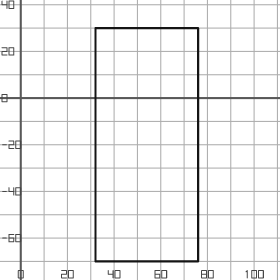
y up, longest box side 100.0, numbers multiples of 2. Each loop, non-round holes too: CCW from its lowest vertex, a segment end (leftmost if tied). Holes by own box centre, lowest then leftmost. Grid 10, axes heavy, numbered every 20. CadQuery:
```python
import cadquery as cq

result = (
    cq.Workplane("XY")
    .moveTo(32.0, -70.0)
    .lineTo(76.0, -70.0)
    .lineTo(76.0, 30.0)
    .lineTo(32.0, 30.0)
    .close()
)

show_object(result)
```